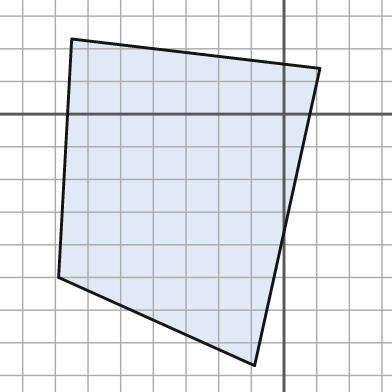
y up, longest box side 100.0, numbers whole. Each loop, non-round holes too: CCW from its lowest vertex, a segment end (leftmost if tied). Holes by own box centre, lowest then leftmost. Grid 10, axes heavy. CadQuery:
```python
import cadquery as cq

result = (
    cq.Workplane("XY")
    .moveTo(-9.0, -77.0)
    .lineTo(11.0, 14.0)
    .lineTo(-65.0, 23.0)
    .lineTo(-69.0, -50.0)
    .close()
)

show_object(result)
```